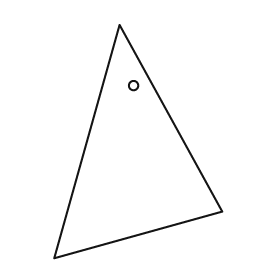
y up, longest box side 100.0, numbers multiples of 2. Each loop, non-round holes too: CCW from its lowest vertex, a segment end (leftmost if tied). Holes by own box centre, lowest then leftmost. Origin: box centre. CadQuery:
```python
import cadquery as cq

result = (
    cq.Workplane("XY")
    .moveTo(-36.0, -50.0)
    .lineTo(36.0, -30.0)
    .lineTo(-8.0, 50.0)
    .close()
    .moveTo(-2.0, 24.0)
    .circle(2.0)
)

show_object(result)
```